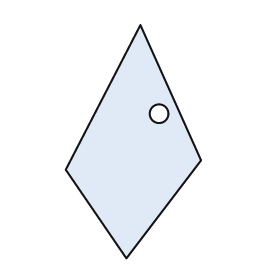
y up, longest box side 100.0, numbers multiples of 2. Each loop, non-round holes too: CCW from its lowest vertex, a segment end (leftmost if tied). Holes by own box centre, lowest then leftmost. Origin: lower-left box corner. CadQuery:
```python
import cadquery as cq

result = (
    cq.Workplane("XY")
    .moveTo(26.0, 0.0)
    .lineTo(58.0, 42.0)
    .lineTo(32.0, 100.0)
    .lineTo(0.0, 38.0)
    .close()
    .moveTo(40.0, 62.0)
    .circle(4.0)
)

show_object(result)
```